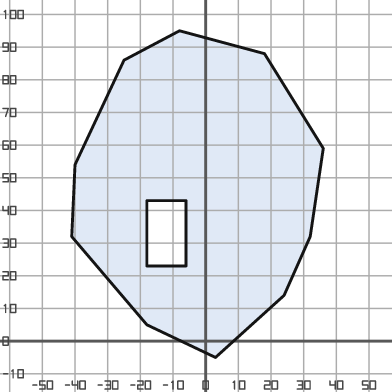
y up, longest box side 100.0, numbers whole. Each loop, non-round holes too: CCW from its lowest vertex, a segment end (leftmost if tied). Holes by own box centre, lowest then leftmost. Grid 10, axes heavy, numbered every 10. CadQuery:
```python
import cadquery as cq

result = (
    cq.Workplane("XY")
    .moveTo(3.0, -5.0)
    .lineTo(24.0, 14.0)
    .lineTo(32.0, 32.0)
    .lineTo(36.0, 59.0)
    .lineTo(18.0, 88.0)
    .lineTo(-8.0, 95.0)
    .lineTo(-25.0, 86.0)
    .lineTo(-40.0, 54.0)
    .lineTo(-41.0, 32.0)
    .lineTo(-18.0, 5.0)
    .close()
    .moveTo(-18.0, 23.0)
    .lineTo(-6.0, 23.0)
    .lineTo(-6.0, 43.0)
    .lineTo(-18.0, 43.0)
    .close()
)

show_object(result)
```